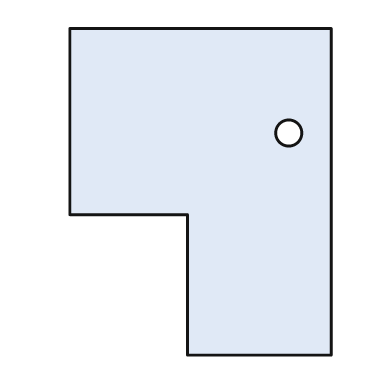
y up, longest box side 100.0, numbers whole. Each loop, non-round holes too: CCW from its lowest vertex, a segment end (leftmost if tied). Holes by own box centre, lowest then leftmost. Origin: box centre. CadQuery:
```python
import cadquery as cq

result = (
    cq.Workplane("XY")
    .moveTo(-4.0, -50.0)
    .lineTo(40.0, -50.0)
    .lineTo(40.0, 50.0)
    .lineTo(-40.0, 50.0)
    .lineTo(-40.0, -7.0)
    .lineTo(-4.0, -7.0)
    .close()
    .moveTo(27.0, 18.0)
    .circle(4.0)
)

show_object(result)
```